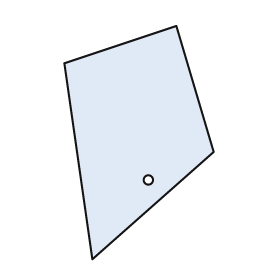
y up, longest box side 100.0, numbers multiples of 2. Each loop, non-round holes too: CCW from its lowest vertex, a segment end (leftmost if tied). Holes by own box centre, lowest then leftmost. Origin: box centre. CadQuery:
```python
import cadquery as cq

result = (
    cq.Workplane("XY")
    .moveTo(-20.0, -50.0)
    .lineTo(32.0, -4.0)
    .lineTo(16.0, 50.0)
    .lineTo(-32.0, 34.0)
    .close()
    .moveTo(4.0, -16.0)
    .circle(2.0)
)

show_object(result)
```